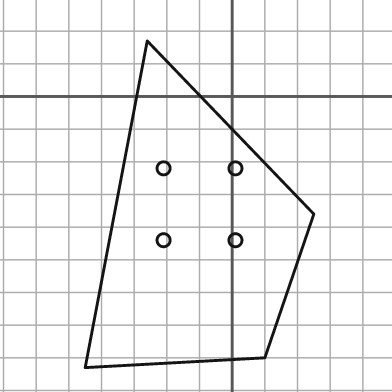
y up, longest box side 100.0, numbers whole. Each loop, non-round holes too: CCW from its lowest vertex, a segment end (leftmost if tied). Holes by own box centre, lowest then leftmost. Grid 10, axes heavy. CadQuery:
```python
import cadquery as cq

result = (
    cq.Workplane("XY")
    .moveTo(-45.0, -83.0)
    .lineTo(10.0, -80.0)
    .lineTo(25.0, -36.0)
    .lineTo(-26.0, 17.0)
    .close()
    .moveTo(-21.0, -44.0)
    .circle(2.0)
    .moveTo(1.0, -44.0)
    .circle(2.0)
    .moveTo(-21.0, -22.0)
    .circle(2.0)
    .moveTo(1.0, -22.0)
    .circle(2.0)
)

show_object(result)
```